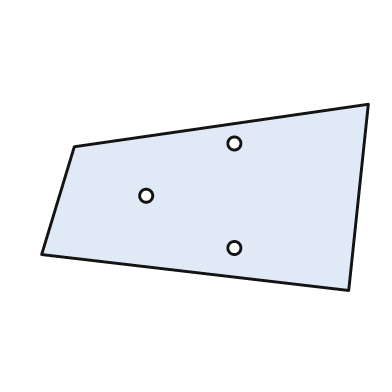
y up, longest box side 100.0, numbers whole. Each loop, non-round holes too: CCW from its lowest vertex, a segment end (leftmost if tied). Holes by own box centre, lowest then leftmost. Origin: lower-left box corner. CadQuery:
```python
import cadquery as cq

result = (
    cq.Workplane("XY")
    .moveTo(94.0, 0.0)
    .lineTo(100.0, 57.0)
    .lineTo(10.0, 44.0)
    .lineTo(0.0, 11.0)
    .close()
    .moveTo(59.0, 13.0)
    .circle(2.0)
    .moveTo(32.0, 29.0)
    .circle(2.0)
    .moveTo(59.0, 45.0)
    .circle(2.0)
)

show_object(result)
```